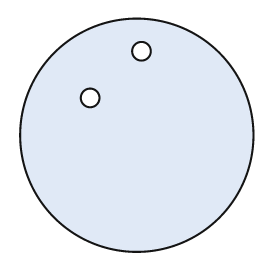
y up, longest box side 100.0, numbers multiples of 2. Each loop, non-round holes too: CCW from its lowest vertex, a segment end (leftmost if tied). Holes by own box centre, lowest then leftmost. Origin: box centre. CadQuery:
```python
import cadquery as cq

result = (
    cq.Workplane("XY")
    .moveTo(0.0, 0.0)
    .circle(50.0)
    .moveTo(-20.0, 16.0)
    .circle(4.0)
    .moveTo(2.0, 36.0)
    .circle(4.0)
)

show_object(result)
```